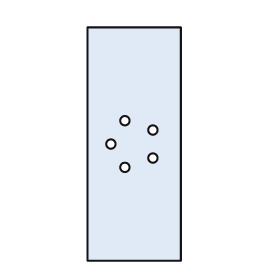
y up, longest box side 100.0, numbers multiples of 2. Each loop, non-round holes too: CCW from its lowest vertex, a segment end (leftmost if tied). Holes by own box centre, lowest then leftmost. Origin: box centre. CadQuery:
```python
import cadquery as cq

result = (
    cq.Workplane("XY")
    .moveTo(-20.0, -50.0)
    .lineTo(20.0, -50.0)
    .lineTo(20.0, 50.0)
    .lineTo(-20.0, 50.0)
    .close()
    .moveTo(-4.0, -10.0)
    .circle(2.0)
    .moveTo(8.0, -6.0)
    .circle(2.0)
    .moveTo(-10.0, 0.0)
    .circle(2.0)
    .moveTo(8.0, 6.0)
    .circle(2.0)
    .moveTo(-4.0, 10.0)
    .circle(2.0)
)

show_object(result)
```